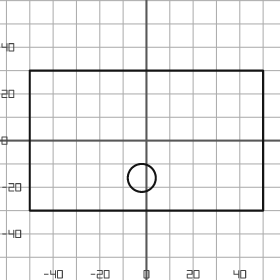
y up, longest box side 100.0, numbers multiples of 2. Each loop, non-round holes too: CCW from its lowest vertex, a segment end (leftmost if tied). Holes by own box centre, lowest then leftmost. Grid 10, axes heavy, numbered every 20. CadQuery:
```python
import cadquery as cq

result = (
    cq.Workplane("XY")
    .moveTo(-50.0, -30.0)
    .lineTo(50.0, -30.0)
    .lineTo(50.0, 30.0)
    .lineTo(-50.0, 30.0)
    .close()
    .moveTo(-2.0, -16.0)
    .circle(6.0)
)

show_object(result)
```